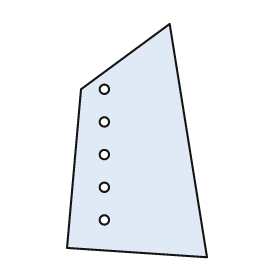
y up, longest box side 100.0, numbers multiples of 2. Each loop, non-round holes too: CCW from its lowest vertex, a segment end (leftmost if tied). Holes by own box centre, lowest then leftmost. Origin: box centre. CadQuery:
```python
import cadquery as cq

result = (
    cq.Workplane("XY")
    .moveTo(30.0, -50.0)
    .lineTo(14.0, 50.0)
    .lineTo(-24.0, 22.0)
    .lineTo(-30.0, -46.0)
    .close()
    .moveTo(-14.0, -34.0)
    .circle(2.0)
    .moveTo(-14.0, -20.0)
    .circle(2.0)
    .moveTo(-14.0, -6.0)
    .circle(2.0)
    .moveTo(-14.0, 8.0)
    .circle(2.0)
    .moveTo(-14.0, 22.0)
    .circle(2.0)
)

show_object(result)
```